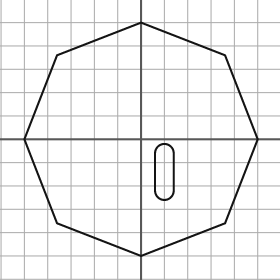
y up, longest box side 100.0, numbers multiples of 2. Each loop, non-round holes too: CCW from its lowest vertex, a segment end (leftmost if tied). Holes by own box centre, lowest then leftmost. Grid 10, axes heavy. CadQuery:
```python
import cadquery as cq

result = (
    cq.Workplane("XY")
    .moveTo(0.0, -50.0)
    .lineTo(36.0, -36.0)
    .lineTo(50.0, 0.0)
    .lineTo(36.0, 36.0)
    .lineTo(0.0, 50.0)
    .lineTo(-36.0, 36.0)
    .lineTo(-50.0, 0.0)
    .lineTo(-36.0, -36.0)
    .close()
    .moveTo(6.0, -22.0)
    .threePointArc((10.0, -26.0), (14.0, -22.0))
    .lineTo(14.0, -6.0)
    .threePointArc((10.0, -2.0), (6.0, -6.0))
    .close()
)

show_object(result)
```